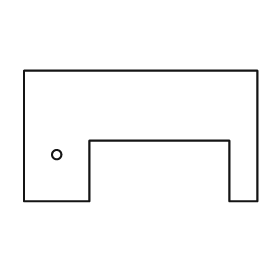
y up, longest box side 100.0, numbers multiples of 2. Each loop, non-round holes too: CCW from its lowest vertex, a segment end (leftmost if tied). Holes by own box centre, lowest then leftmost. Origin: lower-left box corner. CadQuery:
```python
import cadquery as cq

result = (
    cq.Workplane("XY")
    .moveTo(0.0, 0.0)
    .lineTo(28.0, 0.0)
    .lineTo(28.0, 26.0)
    .lineTo(88.0, 26.0)
    .lineTo(88.0, 0.0)
    .lineTo(100.0, 0.0)
    .lineTo(100.0, 56.0)
    .lineTo(0.0, 56.0)
    .close()
    .moveTo(14.0, 20.0)
    .circle(2.0)
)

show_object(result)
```